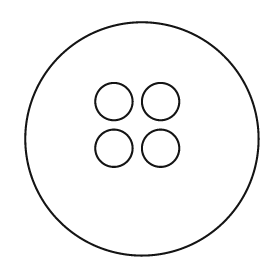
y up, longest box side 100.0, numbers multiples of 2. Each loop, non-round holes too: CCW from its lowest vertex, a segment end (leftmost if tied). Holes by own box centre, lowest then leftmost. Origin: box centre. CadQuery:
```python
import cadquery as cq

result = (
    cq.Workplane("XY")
    .moveTo(0.0, 0.0)
    .circle(50.0)
    .moveTo(-12.0, -4.0)
    .circle(8.0)
    .moveTo(8.0, -4.0)
    .circle(8.0)
    .moveTo(-12.0, 16.0)
    .circle(8.0)
    .moveTo(8.0, 16.0)
    .circle(8.0)
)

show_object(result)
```